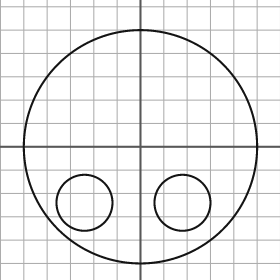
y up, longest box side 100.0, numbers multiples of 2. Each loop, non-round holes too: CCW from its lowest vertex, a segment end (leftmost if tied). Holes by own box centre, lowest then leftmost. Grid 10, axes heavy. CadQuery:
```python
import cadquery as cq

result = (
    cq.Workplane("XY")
    .moveTo(0.0, 0.0)
    .circle(50.0)
    .moveTo(-24.0, -24.0)
    .circle(12.0)
    .moveTo(18.0, -24.0)
    .circle(12.0)
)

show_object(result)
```